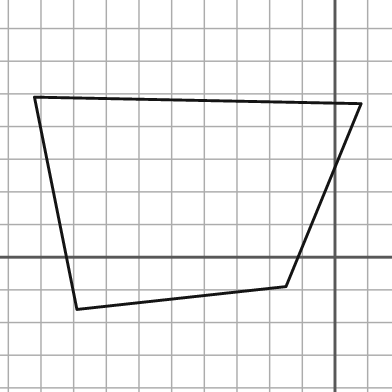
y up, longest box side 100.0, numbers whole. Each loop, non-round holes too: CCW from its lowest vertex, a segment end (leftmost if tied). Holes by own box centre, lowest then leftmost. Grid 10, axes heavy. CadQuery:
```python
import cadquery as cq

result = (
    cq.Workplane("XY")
    .moveTo(-79.0, -16.0)
    .lineTo(-15.0, -9.0)
    .lineTo(8.0, 47.0)
    .lineTo(-92.0, 49.0)
    .close()
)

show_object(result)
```